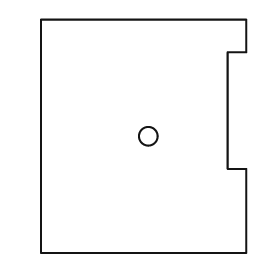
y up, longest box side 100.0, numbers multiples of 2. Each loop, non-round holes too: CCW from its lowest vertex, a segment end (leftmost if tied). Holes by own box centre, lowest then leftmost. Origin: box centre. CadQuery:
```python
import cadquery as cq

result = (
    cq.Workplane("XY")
    .moveTo(-44.0, -50.0)
    .lineTo(44.0, -50.0)
    .lineTo(44.0, -14.0)
    .lineTo(36.0, -14.0)
    .lineTo(36.0, 36.0)
    .lineTo(44.0, 36.0)
    .lineTo(44.0, 50.0)
    .lineTo(-44.0, 50.0)
    .close()
    .moveTo(2.0, 0.0)
    .circle(4.0)
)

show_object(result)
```